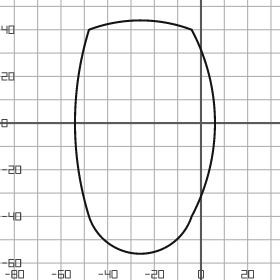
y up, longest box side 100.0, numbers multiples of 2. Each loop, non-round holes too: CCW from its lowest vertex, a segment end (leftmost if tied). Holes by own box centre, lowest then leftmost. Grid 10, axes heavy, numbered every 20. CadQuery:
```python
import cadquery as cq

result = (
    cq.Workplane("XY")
    .moveTo(-48.0, -40.0)
    .threePointArc((-26.0, -56.0), (-4.0, -40.0))
    .threePointArc((6.0, 0.0), (-4.0, 40.0))
    .threePointArc((-26.0, 44.0), (-48.0, 40.0))
    .threePointArc((-54.0, 0.0), (-48.0, -40.0))
    .close()
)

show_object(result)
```